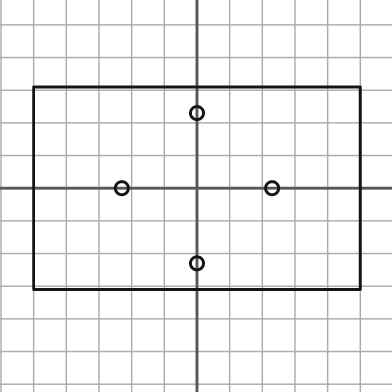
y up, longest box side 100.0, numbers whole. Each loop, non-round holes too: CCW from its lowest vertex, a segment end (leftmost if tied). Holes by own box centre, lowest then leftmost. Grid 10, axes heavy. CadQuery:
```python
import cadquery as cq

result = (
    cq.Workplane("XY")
    .moveTo(-50.0, -31.0)
    .lineTo(50.0, -31.0)
    .lineTo(50.0, 31.0)
    .lineTo(-50.0, 31.0)
    .close()
    .moveTo(0.0, -23.0)
    .circle(2.0)
    .moveTo(-23.0, 0.0)
    .circle(2.0)
    .moveTo(23.0, 0.0)
    .circle(2.0)
    .moveTo(0.0, 23.0)
    .circle(2.0)
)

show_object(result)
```